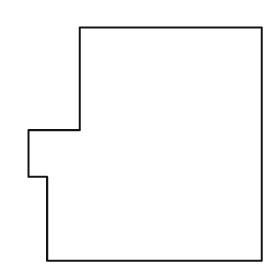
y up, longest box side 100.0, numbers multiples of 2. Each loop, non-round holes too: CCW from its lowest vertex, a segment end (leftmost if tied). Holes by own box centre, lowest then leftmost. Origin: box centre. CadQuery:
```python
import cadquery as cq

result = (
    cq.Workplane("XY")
    .moveTo(-42.0, -50.0)
    .lineTo(50.0, -50.0)
    .lineTo(50.0, 50.0)
    .lineTo(-28.0, 50.0)
    .lineTo(-28.0, 6.0)
    .lineTo(-50.0, 6.0)
    .lineTo(-50.0, -14.0)
    .lineTo(-42.0, -14.0)
    .close()
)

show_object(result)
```